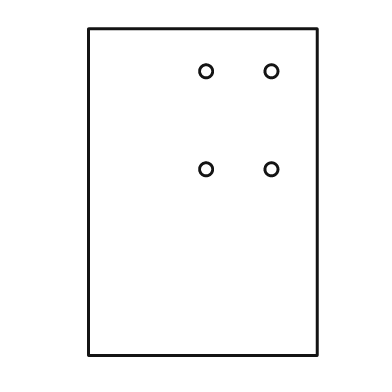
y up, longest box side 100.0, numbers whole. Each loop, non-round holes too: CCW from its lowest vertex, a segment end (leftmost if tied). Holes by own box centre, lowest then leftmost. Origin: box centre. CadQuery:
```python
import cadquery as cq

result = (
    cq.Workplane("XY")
    .moveTo(-35.0, -50.0)
    .lineTo(35.0, -50.0)
    .lineTo(35.0, 50.0)
    .lineTo(-35.0, 50.0)
    .close()
    .moveTo(1.0, 7.0)
    .circle(2.0)
    .moveTo(21.0, 7.0)
    .circle(2.0)
    .moveTo(1.0, 37.0)
    .circle(2.0)
    .moveTo(21.0, 37.0)
    .circle(2.0)
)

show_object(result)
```